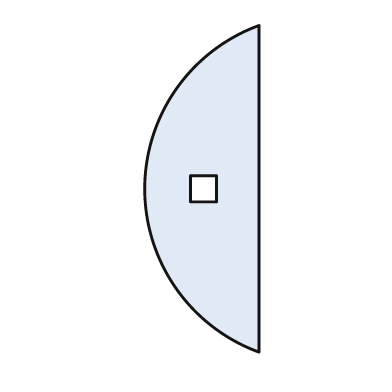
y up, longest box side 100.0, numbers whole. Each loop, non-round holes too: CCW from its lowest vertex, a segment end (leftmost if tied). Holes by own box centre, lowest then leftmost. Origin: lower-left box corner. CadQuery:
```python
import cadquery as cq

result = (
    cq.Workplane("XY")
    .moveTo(35.0, 0.0)
    .lineTo(35.0, 100.0)
    .threePointArc((0.0, 50.0), (35.0, 0.0))
    .close()
    .moveTo(14.0, 46.0)
    .lineTo(22.0, 46.0)
    .lineTo(22.0, 54.0)
    .lineTo(14.0, 54.0)
    .close()
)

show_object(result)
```